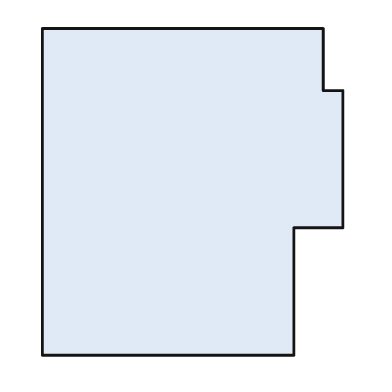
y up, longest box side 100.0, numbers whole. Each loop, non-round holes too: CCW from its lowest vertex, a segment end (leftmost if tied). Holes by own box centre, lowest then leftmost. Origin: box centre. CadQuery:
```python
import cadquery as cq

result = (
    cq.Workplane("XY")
    .moveTo(-46.0, -50.0)
    .lineTo(31.0, -50.0)
    .lineTo(31.0, -11.0)
    .lineTo(46.0, -11.0)
    .lineTo(46.0, 31.0)
    .lineTo(40.0, 31.0)
    .lineTo(40.0, 50.0)
    .lineTo(-46.0, 50.0)
    .close()
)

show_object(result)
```